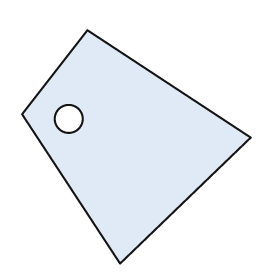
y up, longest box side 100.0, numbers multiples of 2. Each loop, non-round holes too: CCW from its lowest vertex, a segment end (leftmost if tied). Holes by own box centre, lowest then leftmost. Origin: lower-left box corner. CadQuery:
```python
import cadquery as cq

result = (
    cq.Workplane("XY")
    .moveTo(42.0, 0.0)
    .lineTo(98.0, 54.0)
    .lineTo(28.0, 100.0)
    .lineTo(0.0, 64.0)
    .close()
    .moveTo(20.0, 62.0)
    .circle(6.0)
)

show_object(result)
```